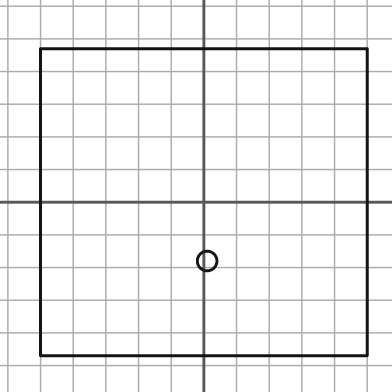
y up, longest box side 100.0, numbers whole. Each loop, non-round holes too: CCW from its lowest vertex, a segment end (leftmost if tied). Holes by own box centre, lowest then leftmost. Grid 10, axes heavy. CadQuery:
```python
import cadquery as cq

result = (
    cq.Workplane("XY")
    .moveTo(-50.0, -47.0)
    .lineTo(50.0, -47.0)
    .lineTo(50.0, 47.0)
    .lineTo(-50.0, 47.0)
    .close()
    .moveTo(1.0, -18.0)
    .circle(3.0)
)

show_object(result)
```